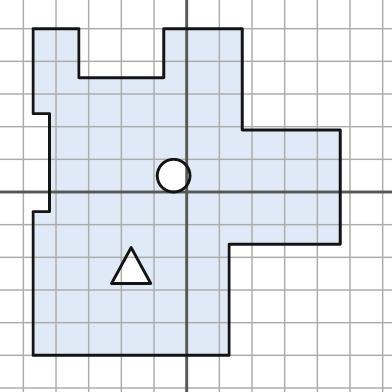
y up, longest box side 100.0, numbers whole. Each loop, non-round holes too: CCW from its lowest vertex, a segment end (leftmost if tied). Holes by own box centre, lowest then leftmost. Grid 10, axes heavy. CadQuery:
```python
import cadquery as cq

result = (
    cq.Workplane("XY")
    .moveTo(-47.0, -50.0)
    .lineTo(13.0, -50.0)
    .lineTo(13.0, -16.0)
    .lineTo(47.0, -16.0)
    .lineTo(47.0, 19.0)
    .lineTo(17.0, 19.0)
    .lineTo(17.0, 50.0)
    .lineTo(-7.0, 50.0)
    .lineTo(-7.0, 35.0)
    .lineTo(-33.0, 35.0)
    .lineTo(-33.0, 50.0)
    .lineTo(-47.0, 50.0)
    .lineTo(-47.0, 24.0)
    .lineTo(-42.0, 24.0)
    .lineTo(-42.0, -6.0)
    .lineTo(-47.0, -6.0)
    .close()
    .moveTo(-23.0, -28.0)
    .lineTo(-11.0, -28.0)
    .lineTo(-17.0, -17.0)
    .close()
    .moveTo(-4.0, 5.0)
    .circle(5.0)
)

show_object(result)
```